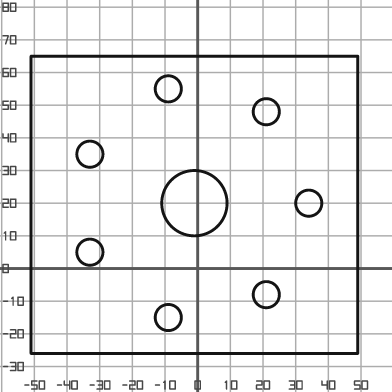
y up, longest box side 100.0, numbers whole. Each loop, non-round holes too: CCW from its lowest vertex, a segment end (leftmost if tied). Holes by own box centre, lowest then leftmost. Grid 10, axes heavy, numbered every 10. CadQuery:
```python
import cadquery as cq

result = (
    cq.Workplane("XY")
    .moveTo(-51.0, -26.0)
    .lineTo(49.0, -26.0)
    .lineTo(49.0, 65.0)
    .lineTo(-51.0, 65.0)
    .close()
    .moveTo(-9.0, -15.0)
    .circle(4.0)
    .moveTo(21.0, -8.0)
    .circle(4.0)
    .moveTo(-33.0, 5.0)
    .circle(4.0)
    .moveTo(-1.0, 20.0)
    .circle(10.0)
    .moveTo(34.0, 20.0)
    .circle(4.0)
    .moveTo(-33.0, 35.0)
    .circle(4.0)
    .moveTo(21.0, 48.0)
    .circle(4.0)
    .moveTo(-9.0, 55.0)
    .circle(4.0)
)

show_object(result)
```